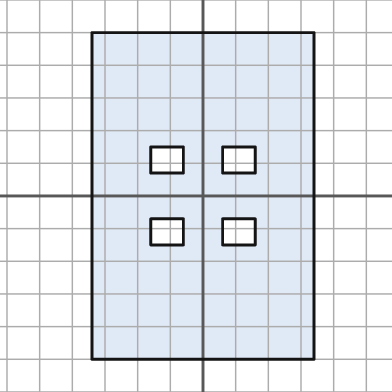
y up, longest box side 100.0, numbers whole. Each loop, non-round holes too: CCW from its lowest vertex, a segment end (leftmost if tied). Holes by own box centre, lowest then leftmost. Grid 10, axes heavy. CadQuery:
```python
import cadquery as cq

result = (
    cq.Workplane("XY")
    .moveTo(-34.0, -50.0)
    .lineTo(34.0, -50.0)
    .lineTo(34.0, 50.0)
    .lineTo(-34.0, 50.0)
    .close()
    .moveTo(-16.0, -15.0)
    .lineTo(-6.0, -15.0)
    .lineTo(-6.0, -7.0)
    .lineTo(-16.0, -7.0)
    .close()
    .moveTo(6.0, -15.0)
    .lineTo(16.0, -15.0)
    .lineTo(16.0, -7.0)
    .lineTo(6.0, -7.0)
    .close()
    .moveTo(-16.0, 7.0)
    .lineTo(-6.0, 7.0)
    .lineTo(-6.0, 15.0)
    .lineTo(-16.0, 15.0)
    .close()
    .moveTo(6.0, 7.0)
    .lineTo(16.0, 7.0)
    .lineTo(16.0, 15.0)
    .lineTo(6.0, 15.0)
    .close()
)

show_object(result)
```